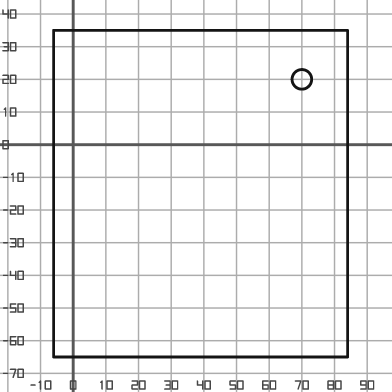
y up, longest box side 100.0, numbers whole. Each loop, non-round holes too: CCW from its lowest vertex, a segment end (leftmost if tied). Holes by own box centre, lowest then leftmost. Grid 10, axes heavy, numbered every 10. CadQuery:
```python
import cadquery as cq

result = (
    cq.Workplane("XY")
    .moveTo(-6.0, -65.0)
    .lineTo(84.0, -65.0)
    .lineTo(84.0, 35.0)
    .lineTo(-6.0, 35.0)
    .close()
    .moveTo(70.0, 20.0)
    .circle(3.0)
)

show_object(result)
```